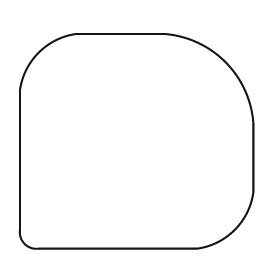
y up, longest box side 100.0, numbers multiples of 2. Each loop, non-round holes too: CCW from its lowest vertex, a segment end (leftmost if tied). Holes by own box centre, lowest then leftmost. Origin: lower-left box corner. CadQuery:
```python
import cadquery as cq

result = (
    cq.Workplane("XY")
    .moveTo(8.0, 0.0)
    .lineTo(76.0, 0.0)
    .threePointArc((92.0, 8.0), (100.0, 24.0))
    .lineTo(100.0, 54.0)
    .threePointArc((88.0, 80.0), (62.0, 92.0))
    .lineTo(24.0, 92.0)
    .threePointArc((8.0, 84.0), (0.0, 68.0))
    .lineTo(0.0, 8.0)
    .threePointArc((2.0, 2.0), (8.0, 0.0))
    .close()
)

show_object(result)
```